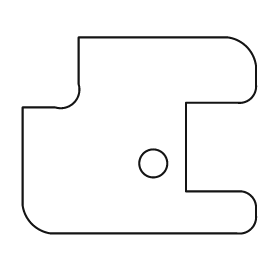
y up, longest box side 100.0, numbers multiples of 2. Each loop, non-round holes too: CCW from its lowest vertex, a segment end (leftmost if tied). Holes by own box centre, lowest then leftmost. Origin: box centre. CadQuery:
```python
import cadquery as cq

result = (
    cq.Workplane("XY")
    .moveTo(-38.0, -42.0)
    .lineTo(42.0, -42.0)
    .threePointArc((48.0, -40.0), (50.0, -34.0))
    .lineTo(50.0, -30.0)
    .threePointArc((48.0, -26.0), (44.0, -24.0))
    .lineTo(20.0, -24.0)
    .lineTo(20.0, 14.0)
    .lineTo(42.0, 14.0)
    .threePointArc((48.0, 16.0), (50.0, 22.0))
    .lineTo(50.0, 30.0)
    .threePointArc((46.0, 38.0), (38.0, 42.0))
    .lineTo(-26.0, 42.0)
    .lineTo(-26.0, 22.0)
    .threePointArc((-28.0, 14.0), (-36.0, 12.0))
    .lineTo(-50.0, 12.0)
    .lineTo(-50.0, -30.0)
    .threePointArc((-46.0, -38.0), (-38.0, -42.0))
    .close()
    .moveTo(6.0, -12.0)
    .circle(6.0)
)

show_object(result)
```